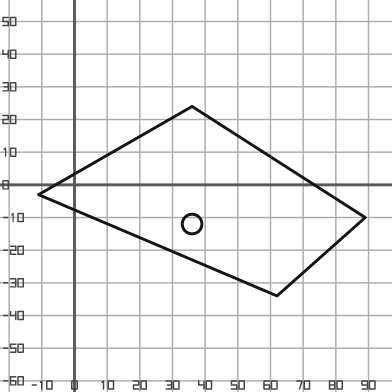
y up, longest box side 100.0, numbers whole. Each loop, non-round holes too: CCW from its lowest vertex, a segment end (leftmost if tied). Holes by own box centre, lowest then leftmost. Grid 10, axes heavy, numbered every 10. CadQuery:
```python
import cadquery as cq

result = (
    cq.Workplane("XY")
    .moveTo(62.0, -34.0)
    .lineTo(89.0, -10.0)
    .lineTo(36.0, 24.0)
    .lineTo(-11.0, -3.0)
    .close()
    .moveTo(36.0, -12.0)
    .circle(3.0)
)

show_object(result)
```